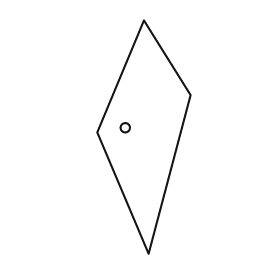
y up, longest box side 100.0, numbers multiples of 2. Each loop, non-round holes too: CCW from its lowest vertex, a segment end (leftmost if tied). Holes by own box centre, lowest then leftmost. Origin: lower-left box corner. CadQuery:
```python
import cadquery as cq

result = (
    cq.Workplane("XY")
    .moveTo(22.0, 0.0)
    .lineTo(40.0, 68.0)
    .lineTo(20.0, 100.0)
    .lineTo(0.0, 52.0)
    .close()
    .moveTo(12.0, 54.0)
    .circle(2.0)
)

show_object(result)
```